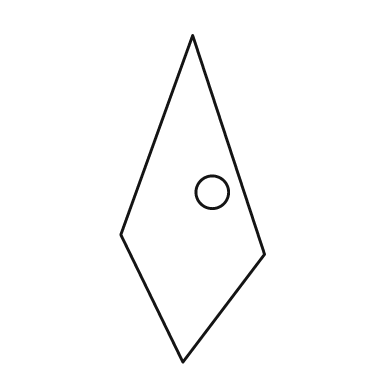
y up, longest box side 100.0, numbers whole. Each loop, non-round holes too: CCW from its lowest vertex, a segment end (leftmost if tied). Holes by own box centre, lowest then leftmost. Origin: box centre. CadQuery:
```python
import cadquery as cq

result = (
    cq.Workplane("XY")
    .moveTo(-3.0, -50.0)
    .lineTo(22.0, -17.0)
    .lineTo(0.0, 50.0)
    .lineTo(-22.0, -11.0)
    .close()
    .moveTo(6.0, 2.0)
    .circle(5.0)
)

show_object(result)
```